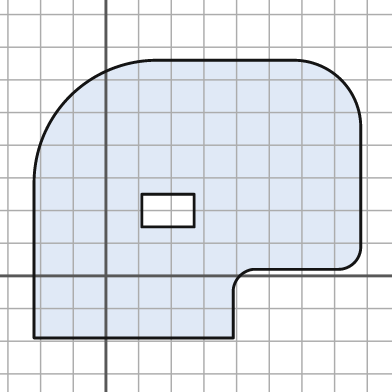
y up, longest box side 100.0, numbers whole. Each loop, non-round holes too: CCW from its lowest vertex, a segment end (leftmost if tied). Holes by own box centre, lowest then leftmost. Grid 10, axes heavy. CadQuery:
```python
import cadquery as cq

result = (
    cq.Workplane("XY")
    .moveTo(-22.0, -19.0)
    .lineTo(39.0, -19.0)
    .lineTo(39.0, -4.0)
    .threePointArc((41.0, 0.0), (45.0, 2.0))
    .lineTo(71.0, 2.0)
    .threePointArc((76.0, 4.0), (78.0, 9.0))
    .lineTo(78.0, 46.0)
    .threePointArc((72.0, 60.0), (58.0, 66.0))
    .lineTo(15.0, 66.0)
    .threePointArc((-11.0, 55.0), (-22.0, 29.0))
    .close()
    .moveTo(11.0, 15.0)
    .lineTo(27.0, 15.0)
    .lineTo(27.0, 25.0)
    .lineTo(11.0, 25.0)
    .close()
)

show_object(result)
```